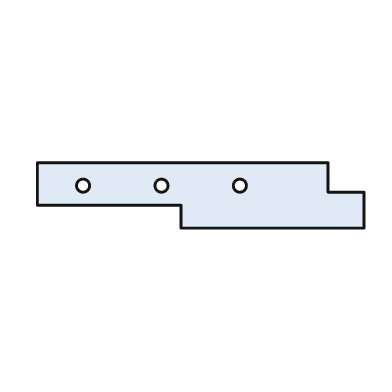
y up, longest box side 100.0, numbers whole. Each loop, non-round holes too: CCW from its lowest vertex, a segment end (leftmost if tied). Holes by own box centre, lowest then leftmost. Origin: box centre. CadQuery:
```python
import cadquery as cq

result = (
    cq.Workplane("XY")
    .moveTo(-6.0, -10.0)
    .lineTo(50.0, -10.0)
    .lineTo(50.0, 1.0)
    .lineTo(39.0, 1.0)
    .lineTo(39.0, 10.0)
    .lineTo(-50.0, 10.0)
    .lineTo(-50.0, -3.0)
    .lineTo(-6.0, -3.0)
    .close()
    .moveTo(-36.0, 3.0)
    .circle(2.0)
    .moveTo(-12.0, 3.0)
    .circle(2.0)
    .moveTo(12.0, 3.0)
    .circle(2.0)
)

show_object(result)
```